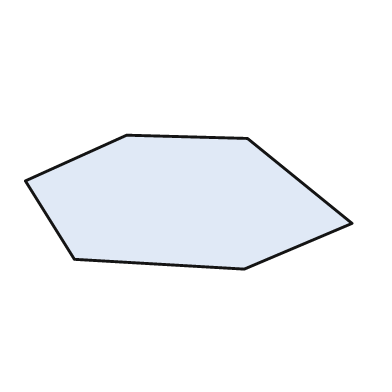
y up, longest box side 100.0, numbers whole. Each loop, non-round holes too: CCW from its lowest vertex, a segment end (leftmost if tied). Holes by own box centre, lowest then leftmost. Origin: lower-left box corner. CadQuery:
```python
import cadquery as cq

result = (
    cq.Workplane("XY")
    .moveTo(67.0, 0.0)
    .lineTo(100.0, 14.0)
    .lineTo(68.0, 40.0)
    .lineTo(31.0, 41.0)
    .lineTo(0.0, 27.0)
    .lineTo(15.0, 3.0)
    .close()
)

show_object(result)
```